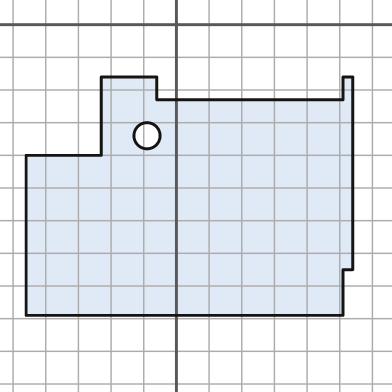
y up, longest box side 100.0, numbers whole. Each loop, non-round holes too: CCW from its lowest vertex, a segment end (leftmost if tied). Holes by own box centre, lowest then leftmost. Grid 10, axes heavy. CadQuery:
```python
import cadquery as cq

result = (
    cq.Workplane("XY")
    .moveTo(-46.0, -89.0)
    .lineTo(51.0, -89.0)
    .lineTo(51.0, -75.0)
    .lineTo(54.0, -75.0)
    .lineTo(54.0, -16.0)
    .lineTo(51.0, -16.0)
    .lineTo(51.0, -23.0)
    .lineTo(-6.0, -23.0)
    .lineTo(-6.0, -16.0)
    .lineTo(-23.0, -16.0)
    .lineTo(-23.0, -40.0)
    .lineTo(-46.0, -40.0)
    .close()
    .moveTo(-9.0, -34.0)
    .circle(4.0)
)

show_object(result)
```